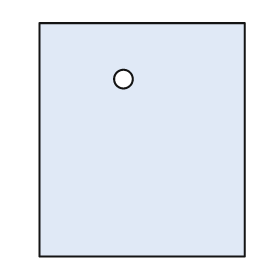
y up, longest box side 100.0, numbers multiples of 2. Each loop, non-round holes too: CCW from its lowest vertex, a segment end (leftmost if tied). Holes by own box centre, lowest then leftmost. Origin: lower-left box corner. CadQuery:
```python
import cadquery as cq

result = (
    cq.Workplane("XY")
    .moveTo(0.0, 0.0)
    .lineTo(88.0, 0.0)
    .lineTo(88.0, 100.0)
    .lineTo(0.0, 100.0)
    .close()
    .moveTo(36.0, 76.0)
    .circle(4.0)
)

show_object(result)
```